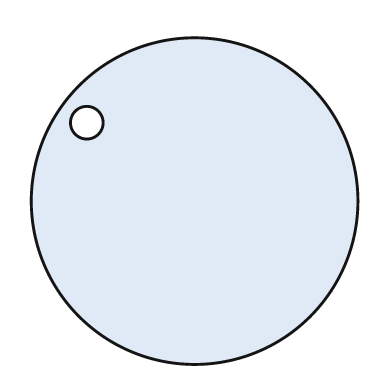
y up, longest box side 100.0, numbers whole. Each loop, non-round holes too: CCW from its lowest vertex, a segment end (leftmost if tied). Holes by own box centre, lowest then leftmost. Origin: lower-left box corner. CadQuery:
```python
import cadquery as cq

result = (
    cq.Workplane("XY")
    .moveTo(50.0, 50.0)
    .circle(50.0)
    .moveTo(17.0, 74.0)
    .circle(5.0)
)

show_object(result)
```